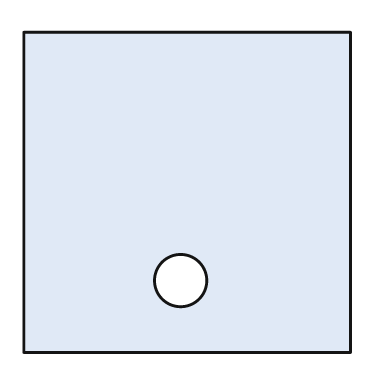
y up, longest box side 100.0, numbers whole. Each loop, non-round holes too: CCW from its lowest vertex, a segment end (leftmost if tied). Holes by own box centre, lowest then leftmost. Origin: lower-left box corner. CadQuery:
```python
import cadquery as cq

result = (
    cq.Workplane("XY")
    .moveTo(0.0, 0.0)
    .lineTo(100.0, 0.0)
    .lineTo(100.0, 98.0)
    .lineTo(0.0, 98.0)
    .close()
    .moveTo(48.0, 22.0)
    .circle(8.0)
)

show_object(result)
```